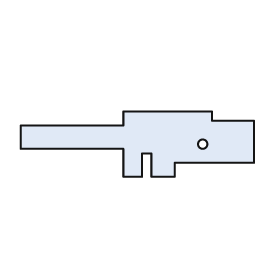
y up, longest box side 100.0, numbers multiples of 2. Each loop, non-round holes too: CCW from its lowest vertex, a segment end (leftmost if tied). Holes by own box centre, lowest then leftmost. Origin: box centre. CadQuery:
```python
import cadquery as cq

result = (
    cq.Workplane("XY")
    .moveTo(-6.0, -14.0)
    .lineTo(2.0, -14.0)
    .lineTo(2.0, -4.0)
    .lineTo(6.0, -4.0)
    .lineTo(6.0, -14.0)
    .lineTo(16.0, -14.0)
    .lineTo(16.0, -8.0)
    .lineTo(50.0, -8.0)
    .lineTo(50.0, 10.0)
    .lineTo(32.0, 10.0)
    .lineTo(32.0, 14.0)
    .lineTo(-6.0, 14.0)
    .lineTo(-6.0, 8.0)
    .lineTo(-50.0, 8.0)
    .lineTo(-50.0, -2.0)
    .lineTo(-6.0, -2.0)
    .close()
    .moveTo(28.0, 0.0)
    .circle(2.0)
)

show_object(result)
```